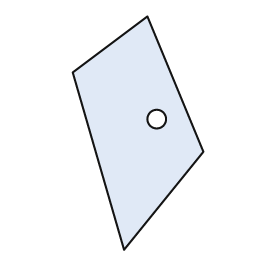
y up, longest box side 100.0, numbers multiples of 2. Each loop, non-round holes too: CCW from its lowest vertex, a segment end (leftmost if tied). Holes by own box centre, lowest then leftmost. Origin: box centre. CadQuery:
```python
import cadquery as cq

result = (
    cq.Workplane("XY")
    .moveTo(-6.0, -50.0)
    .lineTo(28.0, -8.0)
    .lineTo(4.0, 50.0)
    .lineTo(-28.0, 26.0)
    .close()
    .moveTo(8.0, 6.0)
    .circle(4.0)
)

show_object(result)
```